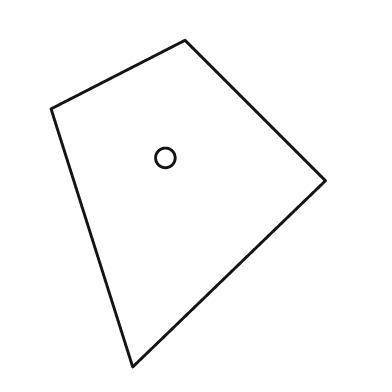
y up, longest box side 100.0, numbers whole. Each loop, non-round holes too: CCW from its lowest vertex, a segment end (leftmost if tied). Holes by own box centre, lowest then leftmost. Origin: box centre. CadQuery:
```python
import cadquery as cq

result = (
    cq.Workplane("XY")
    .moveTo(-17.0, -50.0)
    .lineTo(42.0, 7.0)
    .lineTo(-1.0, 50.0)
    .lineTo(-42.0, 29.0)
    .close()
    .moveTo(-7.0, 14.0)
    .circle(3.0)
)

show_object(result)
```